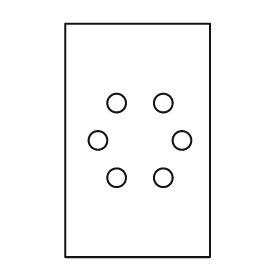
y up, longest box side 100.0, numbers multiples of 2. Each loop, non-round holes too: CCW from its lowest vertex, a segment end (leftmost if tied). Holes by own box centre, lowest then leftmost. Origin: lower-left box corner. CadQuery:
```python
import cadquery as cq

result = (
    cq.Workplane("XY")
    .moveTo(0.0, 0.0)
    .lineTo(62.0, 0.0)
    .lineTo(62.0, 100.0)
    .lineTo(0.0, 100.0)
    .close()
    .moveTo(22.0, 34.0)
    .circle(4.0)
    .moveTo(42.0, 34.0)
    .circle(4.0)
    .moveTo(14.0, 50.0)
    .circle(4.0)
    .moveTo(50.0, 50.0)
    .circle(4.0)
    .moveTo(22.0, 66.0)
    .circle(4.0)
    .moveTo(42.0, 66.0)
    .circle(4.0)
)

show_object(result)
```